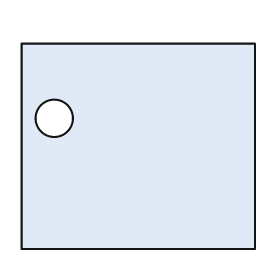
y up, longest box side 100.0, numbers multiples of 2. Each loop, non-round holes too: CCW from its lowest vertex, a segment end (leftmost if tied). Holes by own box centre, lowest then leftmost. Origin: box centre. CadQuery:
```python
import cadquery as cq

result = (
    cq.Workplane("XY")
    .moveTo(-50.0, -44.0)
    .lineTo(50.0, -44.0)
    .lineTo(50.0, 44.0)
    .lineTo(-50.0, 44.0)
    .close()
    .moveTo(-36.0, 12.0)
    .circle(8.0)
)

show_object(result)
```